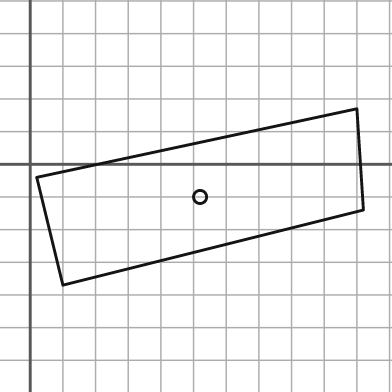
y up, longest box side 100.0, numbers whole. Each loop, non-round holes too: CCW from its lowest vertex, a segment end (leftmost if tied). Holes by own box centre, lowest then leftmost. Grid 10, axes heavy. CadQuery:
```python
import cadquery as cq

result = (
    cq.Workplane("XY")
    .moveTo(10.0, -37.0)
    .lineTo(102.0, -14.0)
    .lineTo(100.0, 17.0)
    .lineTo(2.0, -4.0)
    .close()
    .moveTo(52.0, -10.0)
    .circle(2.0)
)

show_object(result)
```